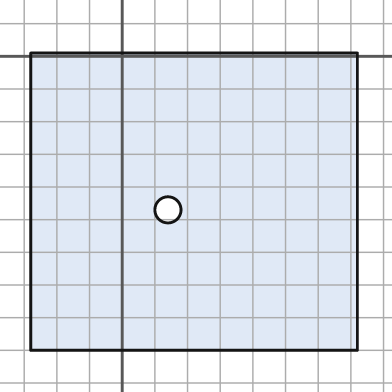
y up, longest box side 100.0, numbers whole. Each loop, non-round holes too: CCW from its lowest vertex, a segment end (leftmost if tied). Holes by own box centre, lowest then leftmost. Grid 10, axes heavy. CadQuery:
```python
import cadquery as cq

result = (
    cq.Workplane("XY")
    .moveTo(-28.0, -90.0)
    .lineTo(72.0, -90.0)
    .lineTo(72.0, 1.0)
    .lineTo(-28.0, 1.0)
    .close()
    .moveTo(14.0, -47.0)
    .circle(4.0)
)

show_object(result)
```